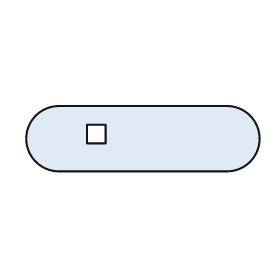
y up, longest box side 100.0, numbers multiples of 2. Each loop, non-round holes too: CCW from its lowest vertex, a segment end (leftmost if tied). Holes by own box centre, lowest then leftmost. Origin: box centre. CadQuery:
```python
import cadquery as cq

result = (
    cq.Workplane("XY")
    .moveTo(-36.0, -14.0)
    .lineTo(36.0, -14.0)
    .threePointArc((50.0, 0.0), (36.0, 14.0))
    .lineTo(-36.0, 14.0)
    .threePointArc((-50.0, 0.0), (-36.0, -14.0))
    .close()
    .moveTo(-24.0, -2.0)
    .lineTo(-16.0, -2.0)
    .lineTo(-16.0, 6.0)
    .lineTo(-24.0, 6.0)
    .close()
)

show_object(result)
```